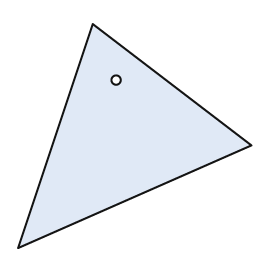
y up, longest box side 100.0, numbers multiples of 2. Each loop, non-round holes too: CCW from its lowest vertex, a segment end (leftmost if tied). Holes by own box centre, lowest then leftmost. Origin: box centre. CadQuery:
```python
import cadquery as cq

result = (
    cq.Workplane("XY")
    .moveTo(-50.0, -48.0)
    .lineTo(50.0, -4.0)
    .lineTo(-18.0, 48.0)
    .close()
    .moveTo(-8.0, 24.0)
    .circle(2.0)
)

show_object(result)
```